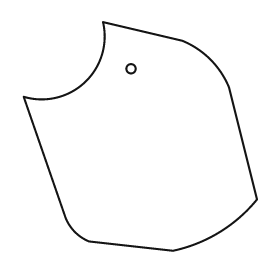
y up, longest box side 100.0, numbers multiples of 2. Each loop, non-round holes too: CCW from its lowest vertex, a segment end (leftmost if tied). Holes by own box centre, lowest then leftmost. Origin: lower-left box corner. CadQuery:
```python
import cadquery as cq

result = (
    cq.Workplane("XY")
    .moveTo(64.0, 0.0)
    .threePointArc((84.0, 8.0), (100.0, 22.0))
    .lineTo(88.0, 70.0)
    .threePointArc((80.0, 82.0), (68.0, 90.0))
    .lineTo(34.0, 98.0)
    .threePointArc((26.0, 72.0), (0.0, 66.0))
    .lineTo(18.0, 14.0)
    .threePointArc((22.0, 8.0), (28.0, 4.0))
    .close()
    .moveTo(46.0, 78.0)
    .circle(2.0)
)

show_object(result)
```